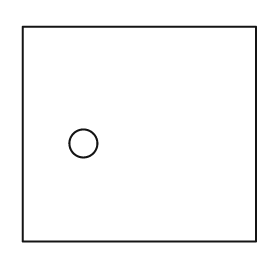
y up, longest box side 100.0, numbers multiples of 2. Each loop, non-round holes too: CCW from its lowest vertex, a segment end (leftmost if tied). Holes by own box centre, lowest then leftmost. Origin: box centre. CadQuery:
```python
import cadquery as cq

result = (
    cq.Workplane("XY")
    .moveTo(-50.0, -46.0)
    .lineTo(50.0, -46.0)
    .lineTo(50.0, 46.0)
    .lineTo(-50.0, 46.0)
    .close()
    .moveTo(-24.0, -4.0)
    .circle(6.0)
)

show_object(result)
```